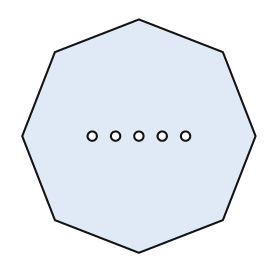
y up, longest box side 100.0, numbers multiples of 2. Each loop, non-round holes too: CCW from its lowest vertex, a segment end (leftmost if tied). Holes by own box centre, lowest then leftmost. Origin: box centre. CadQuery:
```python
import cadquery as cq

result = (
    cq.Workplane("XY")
    .moveTo(0.0, -50.0)
    .lineTo(36.0, -36.0)
    .lineTo(50.0, 0.0)
    .lineTo(36.0, 36.0)
    .lineTo(0.0, 50.0)
    .lineTo(-36.0, 36.0)
    .lineTo(-50.0, 0.0)
    .lineTo(-36.0, -36.0)
    .close()
    .moveTo(-20.0, 0.0)
    .circle(2.0)
    .moveTo(-10.0, 0.0)
    .circle(2.0)
    .moveTo(0.0, 0.0)
    .circle(2.0)
    .moveTo(10.0, 0.0)
    .circle(2.0)
    .moveTo(20.0, 0.0)
    .circle(2.0)
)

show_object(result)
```